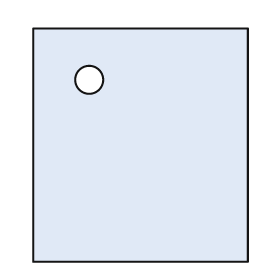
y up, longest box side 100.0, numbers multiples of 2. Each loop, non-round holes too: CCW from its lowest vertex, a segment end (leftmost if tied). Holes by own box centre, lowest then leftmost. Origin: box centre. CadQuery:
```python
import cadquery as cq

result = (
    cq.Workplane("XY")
    .moveTo(-46.0, -50.0)
    .lineTo(46.0, -50.0)
    .lineTo(46.0, 50.0)
    .lineTo(-46.0, 50.0)
    .close()
    .moveTo(-22.0, 28.0)
    .circle(6.0)
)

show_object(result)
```